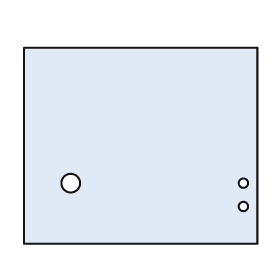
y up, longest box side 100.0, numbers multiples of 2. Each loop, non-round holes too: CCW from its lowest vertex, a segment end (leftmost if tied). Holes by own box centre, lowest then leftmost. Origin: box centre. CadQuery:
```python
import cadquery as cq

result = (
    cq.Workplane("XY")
    .moveTo(-50.0, -42.0)
    .lineTo(50.0, -42.0)
    .lineTo(50.0, 42.0)
    .lineTo(-50.0, 42.0)
    .close()
    .moveTo(44.0, -26.0)
    .circle(2.0)
    .moveTo(-30.0, -16.0)
    .circle(4.0)
    .moveTo(44.0, -16.0)
    .circle(2.0)
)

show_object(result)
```